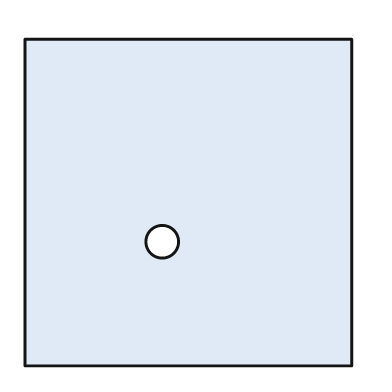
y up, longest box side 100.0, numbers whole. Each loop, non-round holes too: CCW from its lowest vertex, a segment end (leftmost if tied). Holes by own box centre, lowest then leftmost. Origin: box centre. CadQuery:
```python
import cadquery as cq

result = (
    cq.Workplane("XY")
    .moveTo(-50.0, -50.0)
    .lineTo(50.0, -50.0)
    .lineTo(50.0, 50.0)
    .lineTo(-50.0, 50.0)
    .close()
    .moveTo(-8.0, -12.0)
    .circle(5.0)
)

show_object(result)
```